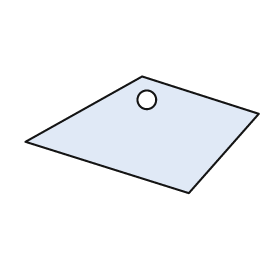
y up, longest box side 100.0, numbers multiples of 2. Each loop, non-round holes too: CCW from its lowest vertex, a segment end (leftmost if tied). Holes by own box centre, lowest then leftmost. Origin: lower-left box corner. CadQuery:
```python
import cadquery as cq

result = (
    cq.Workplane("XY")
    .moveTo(70.0, 0.0)
    .lineTo(100.0, 34.0)
    .lineTo(50.0, 50.0)
    .lineTo(0.0, 22.0)
    .close()
    .moveTo(52.0, 40.0)
    .circle(4.0)
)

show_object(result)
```